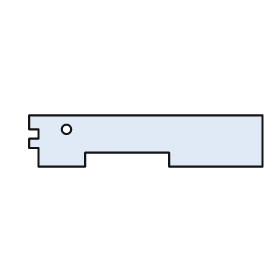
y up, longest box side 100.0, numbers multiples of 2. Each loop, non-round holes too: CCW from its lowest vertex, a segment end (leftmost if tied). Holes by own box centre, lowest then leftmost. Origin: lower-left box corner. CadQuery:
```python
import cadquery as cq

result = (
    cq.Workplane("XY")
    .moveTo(4.0, 0.0)
    .lineTo(24.0, 0.0)
    .lineTo(24.0, 6.0)
    .lineTo(60.0, 6.0)
    .lineTo(60.0, 0.0)
    .lineTo(100.0, 0.0)
    .lineTo(100.0, 22.0)
    .lineTo(0.0, 22.0)
    .lineTo(0.0, 16.0)
    .lineTo(4.0, 16.0)
    .lineTo(4.0, 12.0)
    .lineTo(0.0, 12.0)
    .lineTo(0.0, 8.0)
    .lineTo(4.0, 8.0)
    .close()
    .moveTo(16.0, 16.0)
    .circle(2.0)
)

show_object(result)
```